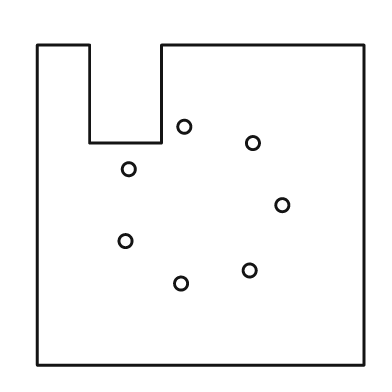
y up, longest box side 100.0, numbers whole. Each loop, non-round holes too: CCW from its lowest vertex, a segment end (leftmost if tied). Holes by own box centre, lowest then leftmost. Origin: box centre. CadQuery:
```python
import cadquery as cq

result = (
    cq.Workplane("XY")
    .moveTo(-50.0, -49.0)
    .lineTo(50.0, -49.0)
    .lineTo(50.0, 49.0)
    .lineTo(-12.0, 49.0)
    .lineTo(-12.0, 19.0)
    .lineTo(-34.0, 19.0)
    .lineTo(-34.0, 49.0)
    .lineTo(-50.0, 49.0)
    .close()
    .moveTo(-6.0, -24.0)
    .circle(2.0)
    .moveTo(15.0, -20.0)
    .circle(2.0)
    .moveTo(-23.0, -11.0)
    .circle(2.0)
    .moveTo(25.0, 0.0)
    .circle(2.0)
    .moveTo(-22.0, 11.0)
    .circle(2.0)
    .moveTo(16.0, 19.0)
    .circle(2.0)
    .moveTo(-5.0, 24.0)
    .circle(2.0)
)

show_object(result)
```